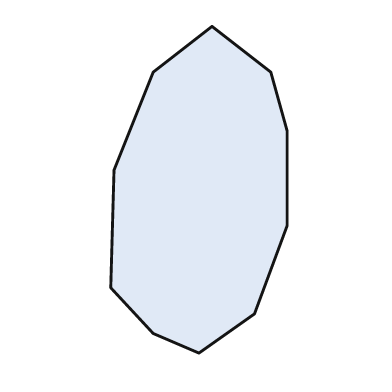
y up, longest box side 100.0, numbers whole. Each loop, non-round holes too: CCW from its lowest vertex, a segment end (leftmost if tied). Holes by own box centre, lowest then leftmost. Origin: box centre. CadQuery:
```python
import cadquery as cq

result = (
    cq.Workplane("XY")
    .moveTo(0.0, -50.0)
    .lineTo(17.0, -38.0)
    .lineTo(27.0, -11.0)
    .lineTo(27.0, 18.0)
    .lineTo(22.0, 36.0)
    .lineTo(4.0, 50.0)
    .lineTo(-14.0, 36.0)
    .lineTo(-26.0, 6.0)
    .lineTo(-27.0, -30.0)
    .lineTo(-14.0, -44.0)
    .close()
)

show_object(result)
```